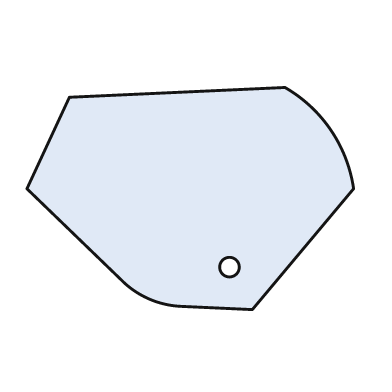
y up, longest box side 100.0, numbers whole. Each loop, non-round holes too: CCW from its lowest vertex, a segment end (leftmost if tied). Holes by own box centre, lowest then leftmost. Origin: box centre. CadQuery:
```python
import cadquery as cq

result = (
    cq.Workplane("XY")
    .moveTo(19.0, -34.0)
    .lineTo(50.0, 3.0)
    .threePointArc((43.0, 21.0), (29.0, 34.0))
    .lineTo(-37.0, 31.0)
    .lineTo(-50.0, 3.0)
    .lineTo(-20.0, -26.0)
    .threePointArc((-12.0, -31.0), (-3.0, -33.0))
    .close()
    .moveTo(12.0, -21.0)
    .circle(3.0)
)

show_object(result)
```